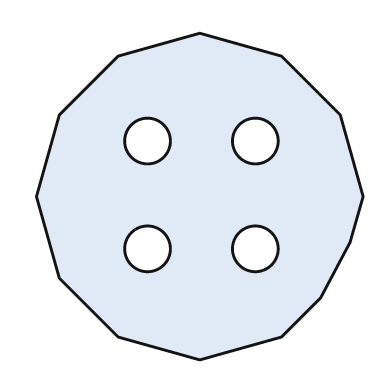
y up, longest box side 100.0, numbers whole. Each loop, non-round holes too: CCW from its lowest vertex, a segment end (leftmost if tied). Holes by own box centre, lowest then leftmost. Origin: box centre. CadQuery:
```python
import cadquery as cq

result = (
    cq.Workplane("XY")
    .moveTo(0.0, -50.0)
    .lineTo(25.0, -43.0)
    .lineTo(37.0, -31.0)
    .lineTo(46.0, -14.0)
    .lineTo(50.0, 0.0)
    .lineTo(43.0, 25.0)
    .lineTo(25.0, 43.0)
    .lineTo(0.0, 50.0)
    .lineTo(-25.0, 43.0)
    .lineTo(-43.0, 25.0)
    .lineTo(-50.0, 0.0)
    .lineTo(-43.0, -25.0)
    .lineTo(-25.0, -43.0)
    .close()
    .moveTo(-16.0, -16.0)
    .circle(7.0)
    .moveTo(17.0, -16.0)
    .circle(7.0)
    .moveTo(-16.0, 17.0)
    .circle(7.0)
    .moveTo(17.0, 17.0)
    .circle(7.0)
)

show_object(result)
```